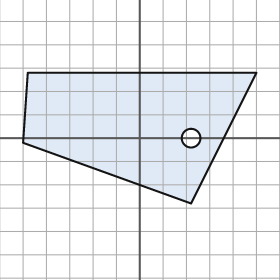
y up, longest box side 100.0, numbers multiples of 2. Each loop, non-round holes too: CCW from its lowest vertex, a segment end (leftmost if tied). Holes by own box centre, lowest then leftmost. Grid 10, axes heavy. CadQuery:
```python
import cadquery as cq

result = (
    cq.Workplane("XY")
    .moveTo(22.0, -28.0)
    .lineTo(50.0, 28.0)
    .lineTo(-48.0, 28.0)
    .lineTo(-50.0, -2.0)
    .close()
    .moveTo(22.0, 0.0)
    .circle(4.0)
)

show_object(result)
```